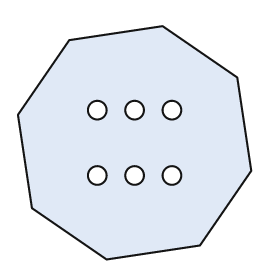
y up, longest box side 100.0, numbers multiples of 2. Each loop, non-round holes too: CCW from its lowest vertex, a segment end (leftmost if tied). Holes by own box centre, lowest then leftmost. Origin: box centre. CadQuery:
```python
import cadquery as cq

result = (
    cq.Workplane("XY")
    .moveTo(-12.0, -50.0)
    .lineTo(28.0, -44.0)
    .lineTo(50.0, -12.0)
    .lineTo(44.0, 28.0)
    .lineTo(12.0, 50.0)
    .lineTo(-28.0, 44.0)
    .lineTo(-50.0, 12.0)
    .lineTo(-44.0, -28.0)
    .close()
    .moveTo(-16.0, -14.0)
    .circle(4.0)
    .moveTo(0.0, -14.0)
    .circle(4.0)
    .moveTo(16.0, -14.0)
    .circle(4.0)
    .moveTo(-16.0, 14.0)
    .circle(4.0)
    .moveTo(0.0, 14.0)
    .circle(4.0)
    .moveTo(16.0, 14.0)
    .circle(4.0)
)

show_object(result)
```